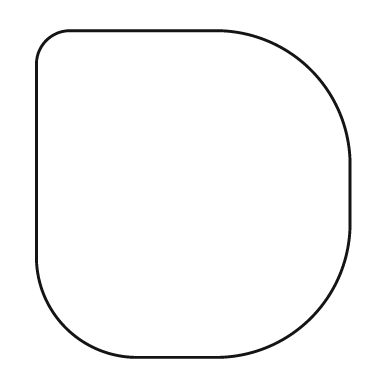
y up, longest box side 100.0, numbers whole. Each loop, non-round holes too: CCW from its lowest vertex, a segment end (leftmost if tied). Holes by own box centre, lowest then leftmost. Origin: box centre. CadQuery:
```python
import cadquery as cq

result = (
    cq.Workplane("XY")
    .moveTo(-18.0, -50.0)
    .lineTo(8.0, -50.0)
    .threePointArc((36.0, -38.0), (48.0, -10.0))
    .lineTo(48.0, 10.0)
    .threePointArc((36.0, 38.0), (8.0, 50.0))
    .lineTo(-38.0, 50.0)
    .threePointArc((-45.0, 47.0), (-48.0, 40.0))
    .lineTo(-48.0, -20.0)
    .threePointArc((-39.0, -41.0), (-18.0, -50.0))
    .close()
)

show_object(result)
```